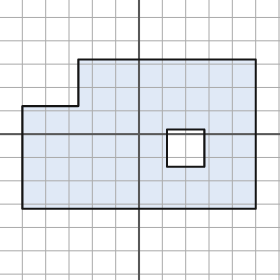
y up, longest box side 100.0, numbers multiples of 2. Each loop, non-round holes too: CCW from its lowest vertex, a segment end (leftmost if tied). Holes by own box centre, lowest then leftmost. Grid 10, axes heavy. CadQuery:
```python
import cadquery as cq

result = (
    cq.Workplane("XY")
    .moveTo(-50.0, -32.0)
    .lineTo(50.0, -32.0)
    .lineTo(50.0, 32.0)
    .lineTo(-26.0, 32.0)
    .lineTo(-26.0, 12.0)
    .lineTo(-50.0, 12.0)
    .close()
    .moveTo(12.0, -14.0)
    .lineTo(28.0, -14.0)
    .lineTo(28.0, 2.0)
    .lineTo(12.0, 2.0)
    .close()
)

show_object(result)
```